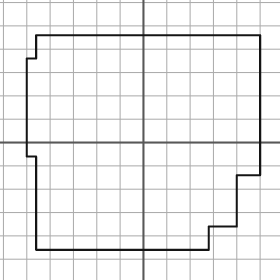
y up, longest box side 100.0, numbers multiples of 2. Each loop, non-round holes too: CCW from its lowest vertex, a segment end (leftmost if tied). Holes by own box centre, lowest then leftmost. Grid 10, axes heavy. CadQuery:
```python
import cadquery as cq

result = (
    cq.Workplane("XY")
    .moveTo(-46.0, -46.0)
    .lineTo(28.0, -46.0)
    .lineTo(28.0, -36.0)
    .lineTo(40.0, -36.0)
    .lineTo(40.0, -14.0)
    .lineTo(50.0, -14.0)
    .lineTo(50.0, 46.0)
    .lineTo(-46.0, 46.0)
    .lineTo(-46.0, 36.0)
    .lineTo(-50.0, 36.0)
    .lineTo(-50.0, -6.0)
    .lineTo(-46.0, -6.0)
    .close()
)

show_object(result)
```